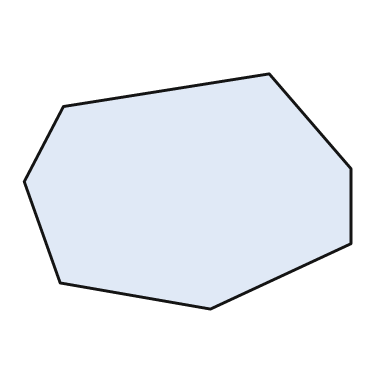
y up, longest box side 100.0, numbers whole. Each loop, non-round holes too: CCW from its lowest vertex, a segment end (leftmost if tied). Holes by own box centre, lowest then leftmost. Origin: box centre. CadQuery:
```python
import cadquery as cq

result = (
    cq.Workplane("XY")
    .moveTo(7.0, -36.0)
    .lineTo(50.0, -16.0)
    .lineTo(50.0, 7.0)
    .lineTo(25.0, 36.0)
    .lineTo(-38.0, 26.0)
    .lineTo(-50.0, 3.0)
    .lineTo(-39.0, -28.0)
    .close()
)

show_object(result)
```